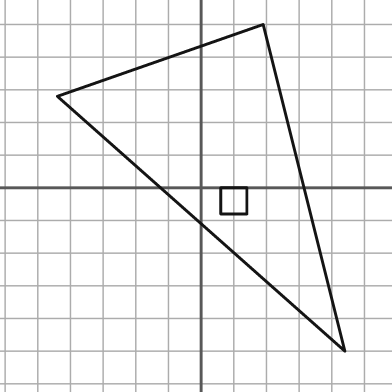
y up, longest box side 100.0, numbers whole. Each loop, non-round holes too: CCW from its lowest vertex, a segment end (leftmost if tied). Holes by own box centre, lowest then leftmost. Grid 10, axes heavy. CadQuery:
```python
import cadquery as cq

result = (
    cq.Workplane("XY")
    .moveTo(44.0, -50.0)
    .lineTo(19.0, 50.0)
    .lineTo(-44.0, 28.0)
    .close()
    .moveTo(6.0, -8.0)
    .lineTo(14.0, -8.0)
    .lineTo(14.0, 0.0)
    .lineTo(6.0, 0.0)
    .close()
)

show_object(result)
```